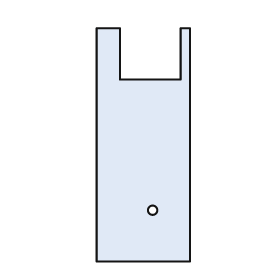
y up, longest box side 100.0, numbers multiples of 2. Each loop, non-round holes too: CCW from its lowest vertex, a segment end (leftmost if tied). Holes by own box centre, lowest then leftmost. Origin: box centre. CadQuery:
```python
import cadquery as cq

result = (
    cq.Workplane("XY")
    .moveTo(-20.0, -50.0)
    .lineTo(20.0, -50.0)
    .lineTo(20.0, 50.0)
    .lineTo(16.0, 50.0)
    .lineTo(16.0, 28.0)
    .lineTo(-10.0, 28.0)
    .lineTo(-10.0, 50.0)
    .lineTo(-20.0, 50.0)
    .close()
    .moveTo(4.0, -28.0)
    .circle(2.0)
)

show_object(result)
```